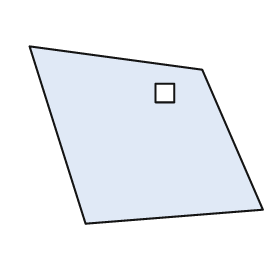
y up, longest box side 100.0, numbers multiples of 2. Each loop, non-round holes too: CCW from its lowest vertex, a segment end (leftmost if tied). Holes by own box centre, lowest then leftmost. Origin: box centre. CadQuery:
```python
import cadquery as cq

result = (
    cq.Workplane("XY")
    .moveTo(-26.0, -38.0)
    .lineTo(50.0, -32.0)
    .lineTo(24.0, 28.0)
    .lineTo(-50.0, 38.0)
    .close()
    .moveTo(4.0, 14.0)
    .lineTo(12.0, 14.0)
    .lineTo(12.0, 22.0)
    .lineTo(4.0, 22.0)
    .close()
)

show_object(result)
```